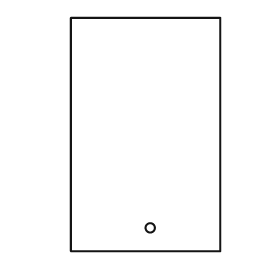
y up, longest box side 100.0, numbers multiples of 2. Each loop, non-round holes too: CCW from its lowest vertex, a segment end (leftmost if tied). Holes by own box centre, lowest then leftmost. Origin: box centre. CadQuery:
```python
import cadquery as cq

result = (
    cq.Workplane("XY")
    .moveTo(-32.0, -50.0)
    .lineTo(32.0, -50.0)
    .lineTo(32.0, 50.0)
    .lineTo(-32.0, 50.0)
    .close()
    .moveTo(2.0, -40.0)
    .circle(2.0)
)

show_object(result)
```